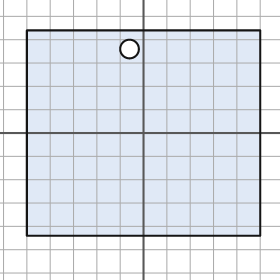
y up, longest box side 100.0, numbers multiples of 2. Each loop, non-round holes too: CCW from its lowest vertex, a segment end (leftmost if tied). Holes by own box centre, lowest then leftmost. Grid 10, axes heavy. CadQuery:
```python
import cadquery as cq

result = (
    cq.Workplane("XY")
    .moveTo(-50.0, -44.0)
    .lineTo(50.0, -44.0)
    .lineTo(50.0, 44.0)
    .lineTo(-50.0, 44.0)
    .close()
    .moveTo(-6.0, 36.0)
    .circle(4.0)
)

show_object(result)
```